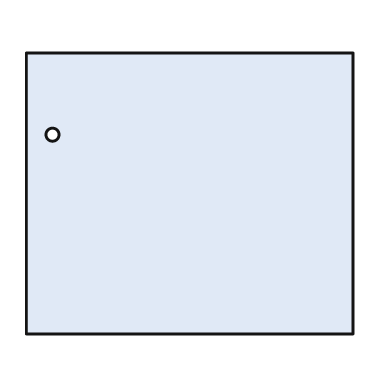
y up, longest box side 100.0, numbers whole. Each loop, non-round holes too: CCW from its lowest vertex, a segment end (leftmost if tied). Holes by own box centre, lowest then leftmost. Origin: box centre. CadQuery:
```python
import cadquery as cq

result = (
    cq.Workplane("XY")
    .moveTo(-50.0, -43.0)
    .lineTo(50.0, -43.0)
    .lineTo(50.0, 43.0)
    .lineTo(-50.0, 43.0)
    .close()
    .moveTo(-42.0, 18.0)
    .circle(2.0)
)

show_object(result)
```